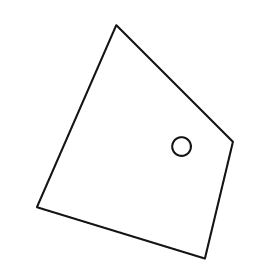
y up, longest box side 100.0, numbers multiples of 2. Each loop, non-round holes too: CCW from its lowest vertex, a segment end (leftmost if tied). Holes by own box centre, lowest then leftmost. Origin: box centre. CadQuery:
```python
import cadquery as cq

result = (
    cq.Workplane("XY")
    .moveTo(30.0, -50.0)
    .lineTo(42.0, 0.0)
    .lineTo(-8.0, 50.0)
    .lineTo(-42.0, -28.0)
    .close()
    .moveTo(20.0, -2.0)
    .circle(4.0)
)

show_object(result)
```